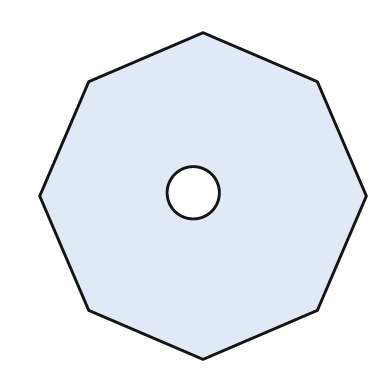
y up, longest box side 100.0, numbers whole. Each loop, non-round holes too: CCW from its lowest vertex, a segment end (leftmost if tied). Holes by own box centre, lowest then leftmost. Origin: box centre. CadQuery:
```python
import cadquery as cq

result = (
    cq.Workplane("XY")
    .moveTo(0.0, -50.0)
    .lineTo(35.0, -35.0)
    .lineTo(50.0, 0.0)
    .lineTo(35.0, 35.0)
    .lineTo(0.0, 50.0)
    .lineTo(-35.0, 35.0)
    .lineTo(-50.0, 0.0)
    .lineTo(-35.0, -35.0)
    .close()
    .moveTo(-3.0, 1.0)
    .circle(8.0)
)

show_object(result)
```